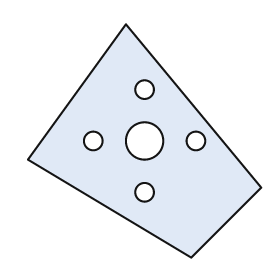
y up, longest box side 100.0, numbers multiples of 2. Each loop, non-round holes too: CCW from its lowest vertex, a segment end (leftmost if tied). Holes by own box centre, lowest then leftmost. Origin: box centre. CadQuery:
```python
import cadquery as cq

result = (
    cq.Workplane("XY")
    .moveTo(20.0, -50.0)
    .lineTo(50.0, -20.0)
    .lineTo(-8.0, 50.0)
    .lineTo(-50.0, -8.0)
    .close()
    .moveTo(0.0, -22.0)
    .circle(4.0)
    .moveTo(-22.0, 0.0)
    .circle(4.0)
    .moveTo(0.0, 0.0)
    .circle(8.0)
    .moveTo(22.0, 0.0)
    .circle(4.0)
    .moveTo(0.0, 22.0)
    .circle(4.0)
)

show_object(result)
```